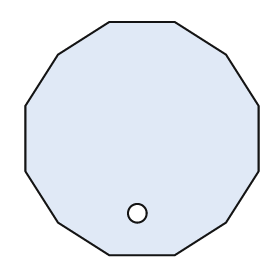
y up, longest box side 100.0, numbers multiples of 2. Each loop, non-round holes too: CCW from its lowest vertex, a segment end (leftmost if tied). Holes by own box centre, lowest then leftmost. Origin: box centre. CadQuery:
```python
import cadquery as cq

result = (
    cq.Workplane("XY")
    .moveTo(-14.0, -50.0)
    .lineTo(14.0, -50.0)
    .lineTo(36.0, -36.0)
    .lineTo(50.0, -14.0)
    .lineTo(50.0, 14.0)
    .lineTo(36.0, 36.0)
    .lineTo(14.0, 50.0)
    .lineTo(-14.0, 50.0)
    .lineTo(-36.0, 36.0)
    .lineTo(-50.0, 14.0)
    .lineTo(-50.0, -14.0)
    .lineTo(-36.0, -36.0)
    .close()
    .moveTo(-2.0, -32.0)
    .circle(4.0)
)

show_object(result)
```